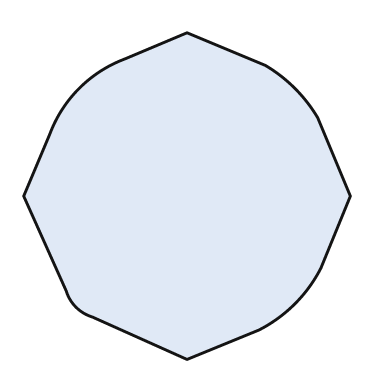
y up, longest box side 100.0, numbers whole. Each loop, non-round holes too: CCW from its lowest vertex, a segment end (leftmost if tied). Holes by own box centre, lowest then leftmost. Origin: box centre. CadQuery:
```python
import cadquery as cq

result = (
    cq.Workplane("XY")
    .moveTo(0.0, -50.0)
    .lineTo(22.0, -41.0)
    .threePointArc((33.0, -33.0), (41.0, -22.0))
    .lineTo(50.0, 0.0)
    .lineTo(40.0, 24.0)
    .threePointArc((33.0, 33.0), (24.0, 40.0))
    .lineTo(0.0, 50.0)
    .lineTo(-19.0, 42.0)
    .threePointArc((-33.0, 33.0), (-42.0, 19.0))
    .lineTo(-50.0, 0.0)
    .lineTo(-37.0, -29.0)
    .threePointArc((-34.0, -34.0), (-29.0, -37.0))
    .close()
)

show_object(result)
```